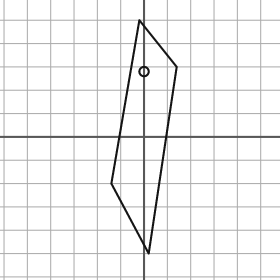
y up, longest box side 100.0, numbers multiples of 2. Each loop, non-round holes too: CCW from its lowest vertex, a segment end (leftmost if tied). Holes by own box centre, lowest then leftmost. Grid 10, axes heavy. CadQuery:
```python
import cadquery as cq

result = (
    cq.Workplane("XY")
    .moveTo(2.0, -50.0)
    .lineTo(14.0, 30.0)
    .lineTo(-2.0, 50.0)
    .lineTo(-14.0, -20.0)
    .close()
    .moveTo(0.0, 28.0)
    .circle(2.0)
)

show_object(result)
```